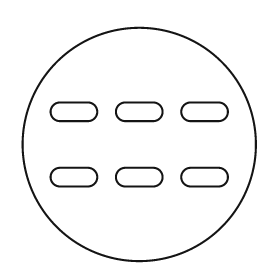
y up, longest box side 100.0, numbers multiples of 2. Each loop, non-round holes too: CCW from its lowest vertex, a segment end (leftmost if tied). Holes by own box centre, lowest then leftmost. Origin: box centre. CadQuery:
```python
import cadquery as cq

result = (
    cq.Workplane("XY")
    .moveTo(0.0, 0.0)
    .circle(50.0)
    .moveTo(-34.0, -18.0)
    .lineTo(-22.0, -18.0)
    .threePointArc((-18.0, -14.0), (-22.0, -10.0))
    .lineTo(-34.0, -10.0)
    .threePointArc((-38.0, -14.0), (-34.0, -18.0))
    .close()
    .moveTo(-6.0, -18.0)
    .lineTo(6.0, -18.0)
    .threePointArc((10.0, -14.0), (6.0, -10.0))
    .lineTo(-6.0, -10.0)
    .threePointArc((-10.0, -14.0), (-6.0, -18.0))
    .close()
    .moveTo(22.0, -18.0)
    .lineTo(34.0, -18.0)
    .threePointArc((38.0, -14.0), (34.0, -10.0))
    .lineTo(22.0, -10.0)
    .threePointArc((18.0, -14.0), (22.0, -18.0))
    .close()
    .moveTo(-34.0, 10.0)
    .lineTo(-22.0, 10.0)
    .threePointArc((-18.0, 14.0), (-22.0, 18.0))
    .lineTo(-34.0, 18.0)
    .threePointArc((-38.0, 14.0), (-34.0, 10.0))
    .close()
    .moveTo(-6.0, 10.0)
    .lineTo(6.0, 10.0)
    .threePointArc((10.0, 14.0), (6.0, 18.0))
    .lineTo(-6.0, 18.0)
    .threePointArc((-10.0, 14.0), (-6.0, 10.0))
    .close()
    .moveTo(22.0, 10.0)
    .lineTo(34.0, 10.0)
    .threePointArc((38.0, 14.0), (34.0, 18.0))
    .lineTo(22.0, 18.0)
    .threePointArc((18.0, 14.0), (22.0, 10.0))
    .close()
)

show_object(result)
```